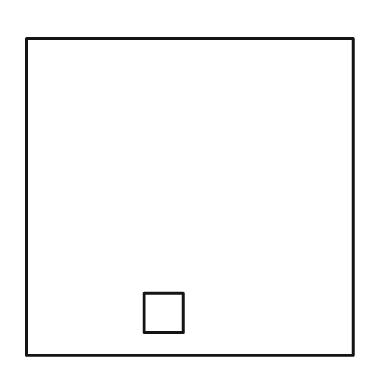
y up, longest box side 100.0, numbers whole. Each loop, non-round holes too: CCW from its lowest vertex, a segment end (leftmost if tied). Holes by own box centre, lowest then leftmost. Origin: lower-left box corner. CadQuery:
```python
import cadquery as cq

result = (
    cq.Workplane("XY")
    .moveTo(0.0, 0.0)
    .lineTo(100.0, 0.0)
    .lineTo(100.0, 97.0)
    .lineTo(0.0, 97.0)
    .close()
    .moveTo(36.0, 7.0)
    .lineTo(48.0, 7.0)
    .lineTo(48.0, 19.0)
    .lineTo(36.0, 19.0)
    .close()
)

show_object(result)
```